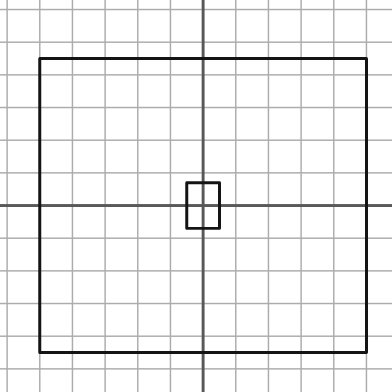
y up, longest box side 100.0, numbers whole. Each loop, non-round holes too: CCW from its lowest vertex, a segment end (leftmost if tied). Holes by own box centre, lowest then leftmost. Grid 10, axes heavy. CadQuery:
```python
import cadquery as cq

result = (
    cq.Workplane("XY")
    .moveTo(-50.0, -45.0)
    .lineTo(50.0, -45.0)
    .lineTo(50.0, 45.0)
    .lineTo(-50.0, 45.0)
    .close()
    .moveTo(-5.0, -7.0)
    .lineTo(5.0, -7.0)
    .lineTo(5.0, 7.0)
    .lineTo(-5.0, 7.0)
    .close()
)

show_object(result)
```